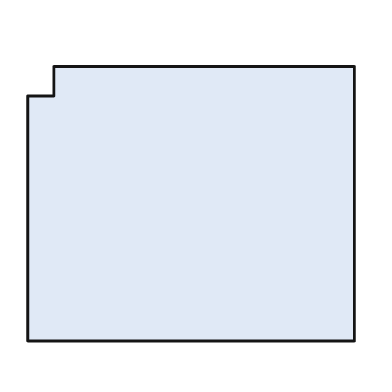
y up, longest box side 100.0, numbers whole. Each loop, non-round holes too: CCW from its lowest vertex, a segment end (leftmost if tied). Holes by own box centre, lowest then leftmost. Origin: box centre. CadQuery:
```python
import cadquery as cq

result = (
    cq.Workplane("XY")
    .moveTo(-50.0, -42.0)
    .lineTo(50.0, -42.0)
    .lineTo(50.0, 42.0)
    .lineTo(-42.0, 42.0)
    .lineTo(-42.0, 33.0)
    .lineTo(-50.0, 33.0)
    .close()
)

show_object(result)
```